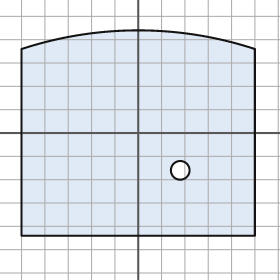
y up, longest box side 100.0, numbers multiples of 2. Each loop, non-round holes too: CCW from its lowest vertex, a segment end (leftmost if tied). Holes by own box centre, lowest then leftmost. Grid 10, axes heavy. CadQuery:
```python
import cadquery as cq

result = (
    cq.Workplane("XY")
    .moveTo(-50.0, -44.0)
    .lineTo(50.0, -44.0)
    .lineTo(50.0, 36.0)
    .threePointArc((0.0, 44.0), (-50.0, 36.0))
    .close()
    .moveTo(18.0, -16.0)
    .circle(4.0)
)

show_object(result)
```